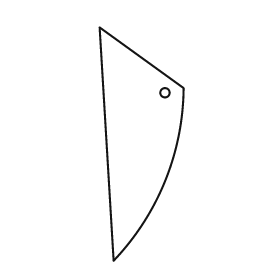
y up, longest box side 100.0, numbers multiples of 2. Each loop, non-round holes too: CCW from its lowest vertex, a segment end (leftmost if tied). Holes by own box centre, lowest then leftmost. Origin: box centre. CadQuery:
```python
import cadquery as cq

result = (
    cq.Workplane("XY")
    .moveTo(-12.0, -50.0)
    .threePointArc((10.0, -16.0), (18.0, 24.0))
    .lineTo(-18.0, 50.0)
    .close()
    .moveTo(10.0, 22.0)
    .circle(2.0)
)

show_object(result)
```